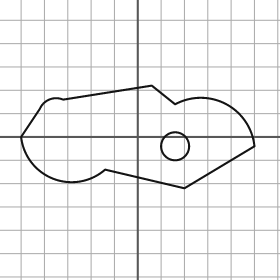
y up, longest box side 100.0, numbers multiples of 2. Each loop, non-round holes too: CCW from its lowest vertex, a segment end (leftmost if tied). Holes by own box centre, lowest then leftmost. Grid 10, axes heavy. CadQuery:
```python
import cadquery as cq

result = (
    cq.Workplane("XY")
    .moveTo(20.0, -22.0)
    .lineTo(50.0, -4.0)
    .threePointArc((38.0, 14.0), (16.0, 14.0))
    .lineTo(6.0, 22.0)
    .lineTo(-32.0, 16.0)
    .threePointArc((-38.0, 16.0), (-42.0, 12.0))
    .lineTo(-50.0, 0.0)
    .threePointArc((-36.0, -18.0), (-14.0, -14.0))
    .close()
    .moveTo(16.0, -4.0)
    .circle(6.0)
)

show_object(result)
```